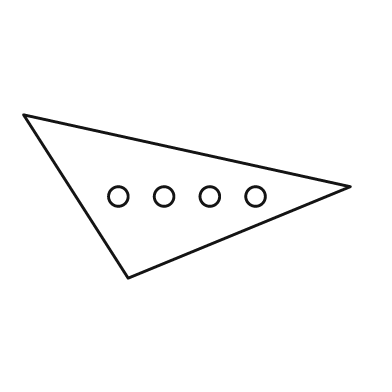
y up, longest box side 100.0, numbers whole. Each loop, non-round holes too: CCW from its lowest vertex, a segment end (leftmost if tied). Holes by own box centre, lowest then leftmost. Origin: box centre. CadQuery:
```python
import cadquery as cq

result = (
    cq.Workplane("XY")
    .moveTo(-18.0, -25.0)
    .lineTo(50.0, 3.0)
    .lineTo(-50.0, 25.0)
    .close()
    .moveTo(-21.0, 0.0)
    .circle(3.0)
    .moveTo(-7.0, 0.0)
    .circle(3.0)
    .moveTo(7.0, 0.0)
    .circle(3.0)
    .moveTo(21.0, 0.0)
    .circle(3.0)
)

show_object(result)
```